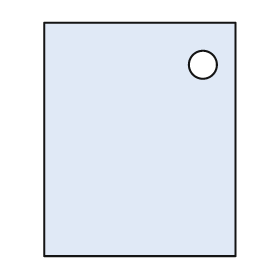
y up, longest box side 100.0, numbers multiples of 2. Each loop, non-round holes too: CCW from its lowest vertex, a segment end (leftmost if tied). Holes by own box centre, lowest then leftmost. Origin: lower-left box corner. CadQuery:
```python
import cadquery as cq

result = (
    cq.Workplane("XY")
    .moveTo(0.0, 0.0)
    .lineTo(82.0, 0.0)
    .lineTo(82.0, 100.0)
    .lineTo(0.0, 100.0)
    .close()
    .moveTo(68.0, 82.0)
    .circle(6.0)
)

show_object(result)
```